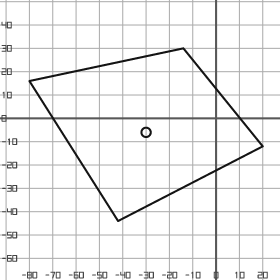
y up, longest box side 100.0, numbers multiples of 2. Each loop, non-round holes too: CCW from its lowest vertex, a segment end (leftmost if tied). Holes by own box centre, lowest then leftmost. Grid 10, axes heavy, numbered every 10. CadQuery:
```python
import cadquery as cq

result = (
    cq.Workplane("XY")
    .moveTo(-42.0, -44.0)
    .lineTo(20.0, -12.0)
    .lineTo(-14.0, 30.0)
    .lineTo(-80.0, 16.0)
    .close()
    .moveTo(-30.0, -6.0)
    .circle(2.0)
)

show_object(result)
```